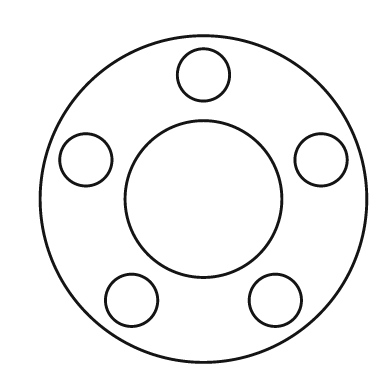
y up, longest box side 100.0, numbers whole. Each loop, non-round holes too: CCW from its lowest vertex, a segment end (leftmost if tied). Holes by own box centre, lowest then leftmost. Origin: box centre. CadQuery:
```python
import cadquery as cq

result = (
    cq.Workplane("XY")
    .moveTo(0.0, 0.0)
    .circle(50.0)
    .moveTo(-22.0, -31.0)
    .circle(8.0)
    .moveTo(22.0, -31.0)
    .circle(8.0)
    .moveTo(0.0, 0.0)
    .circle(24.0)
    .moveTo(-36.0, 12.0)
    .circle(8.0)
    .moveTo(36.0, 12.0)
    .circle(8.0)
    .moveTo(0.0, 38.0)
    .circle(8.0)
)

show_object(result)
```